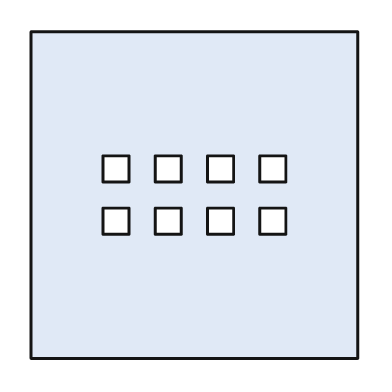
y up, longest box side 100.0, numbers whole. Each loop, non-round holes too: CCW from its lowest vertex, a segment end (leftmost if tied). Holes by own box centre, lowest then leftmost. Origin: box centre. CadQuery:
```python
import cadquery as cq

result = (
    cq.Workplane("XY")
    .moveTo(-50.0, -50.0)
    .lineTo(50.0, -50.0)
    .lineTo(50.0, 50.0)
    .lineTo(-50.0, 50.0)
    .close()
    .moveTo(-28.0, -12.0)
    .lineTo(-20.0, -12.0)
    .lineTo(-20.0, -4.0)
    .lineTo(-28.0, -4.0)
    .close()
    .moveTo(-12.0, -12.0)
    .lineTo(-4.0, -12.0)
    .lineTo(-4.0, -4.0)
    .lineTo(-12.0, -4.0)
    .close()
    .moveTo(4.0, -12.0)
    .lineTo(12.0, -12.0)
    .lineTo(12.0, -4.0)
    .lineTo(4.0, -4.0)
    .close()
    .moveTo(20.0, -12.0)
    .lineTo(28.0, -12.0)
    .lineTo(28.0, -4.0)
    .lineTo(20.0, -4.0)
    .close()
    .moveTo(-28.0, 4.0)
    .lineTo(-20.0, 4.0)
    .lineTo(-20.0, 12.0)
    .lineTo(-28.0, 12.0)
    .close()
    .moveTo(-12.0, 4.0)
    .lineTo(-4.0, 4.0)
    .lineTo(-4.0, 12.0)
    .lineTo(-12.0, 12.0)
    .close()
    .moveTo(4.0, 4.0)
    .lineTo(12.0, 4.0)
    .lineTo(12.0, 12.0)
    .lineTo(4.0, 12.0)
    .close()
    .moveTo(20.0, 4.0)
    .lineTo(28.0, 4.0)
    .lineTo(28.0, 12.0)
    .lineTo(20.0, 12.0)
    .close()
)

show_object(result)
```